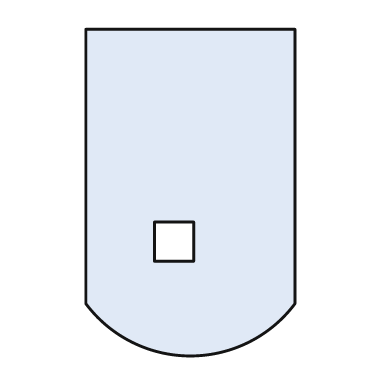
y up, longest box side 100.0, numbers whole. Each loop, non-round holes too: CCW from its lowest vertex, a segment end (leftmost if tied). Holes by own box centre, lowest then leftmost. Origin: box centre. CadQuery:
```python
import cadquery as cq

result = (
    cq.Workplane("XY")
    .moveTo(-32.0, -34.0)
    .threePointArc((0.0, -50.0), (32.0, -34.0))
    .lineTo(32.0, 50.0)
    .lineTo(-32.0, 50.0)
    .close()
    .moveTo(-11.0, -21.0)
    .lineTo(1.0, -21.0)
    .lineTo(1.0, -9.0)
    .lineTo(-11.0, -9.0)
    .close()
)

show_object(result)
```